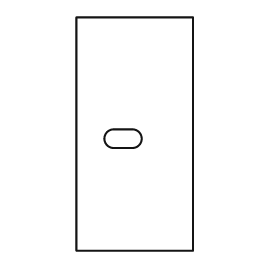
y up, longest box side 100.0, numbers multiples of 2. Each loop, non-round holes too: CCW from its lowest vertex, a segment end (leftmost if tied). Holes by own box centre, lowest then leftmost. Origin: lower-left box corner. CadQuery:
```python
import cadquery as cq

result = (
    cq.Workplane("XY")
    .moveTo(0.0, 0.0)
    .lineTo(50.0, 0.0)
    .lineTo(50.0, 100.0)
    .lineTo(0.0, 100.0)
    .close()
    .moveTo(16.0, 44.0)
    .lineTo(24.0, 44.0)
    .threePointArc((28.0, 48.0), (24.0, 52.0))
    .lineTo(16.0, 52.0)
    .threePointArc((12.0, 48.0), (16.0, 44.0))
    .close()
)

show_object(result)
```